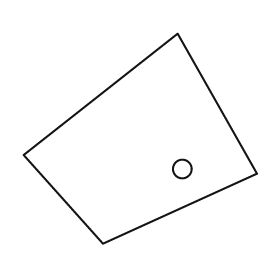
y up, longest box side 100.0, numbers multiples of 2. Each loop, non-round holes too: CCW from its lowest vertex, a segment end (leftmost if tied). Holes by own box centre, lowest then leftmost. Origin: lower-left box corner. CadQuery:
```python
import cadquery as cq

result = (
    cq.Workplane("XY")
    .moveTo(34.0, 0.0)
    .lineTo(100.0, 30.0)
    .lineTo(66.0, 90.0)
    .lineTo(0.0, 38.0)
    .close()
    .moveTo(68.0, 32.0)
    .circle(4.0)
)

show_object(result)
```